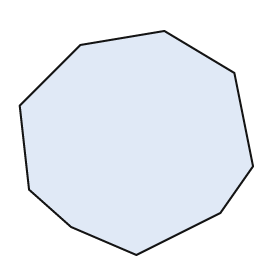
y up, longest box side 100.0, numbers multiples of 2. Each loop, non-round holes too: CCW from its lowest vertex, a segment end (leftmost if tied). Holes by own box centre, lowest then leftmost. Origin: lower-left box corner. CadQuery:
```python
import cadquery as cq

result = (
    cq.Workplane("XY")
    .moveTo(50.0, 0.0)
    .lineTo(86.0, 18.0)
    .lineTo(100.0, 38.0)
    .lineTo(92.0, 78.0)
    .lineTo(62.0, 96.0)
    .lineTo(26.0, 90.0)
    .lineTo(0.0, 64.0)
    .lineTo(4.0, 28.0)
    .lineTo(22.0, 12.0)
    .close()
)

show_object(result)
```